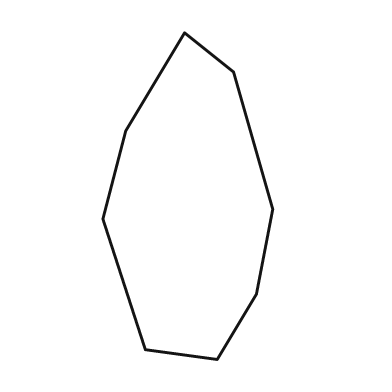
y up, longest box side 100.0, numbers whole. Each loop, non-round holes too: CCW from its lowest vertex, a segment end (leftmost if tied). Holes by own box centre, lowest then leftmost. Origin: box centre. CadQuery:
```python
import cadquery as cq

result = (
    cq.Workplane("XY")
    .moveTo(9.0, -50.0)
    .lineTo(21.0, -30.0)
    .lineTo(26.0, -4.0)
    .lineTo(14.0, 38.0)
    .lineTo(-1.0, 50.0)
    .lineTo(-19.0, 20.0)
    .lineTo(-26.0, -7.0)
    .lineTo(-13.0, -47.0)
    .close()
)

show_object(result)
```